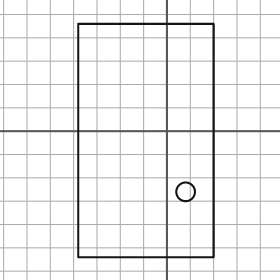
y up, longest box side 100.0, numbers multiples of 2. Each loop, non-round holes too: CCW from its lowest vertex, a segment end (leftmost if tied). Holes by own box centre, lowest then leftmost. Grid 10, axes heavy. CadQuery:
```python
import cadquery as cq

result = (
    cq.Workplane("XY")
    .moveTo(-38.0, -54.0)
    .lineTo(20.0, -54.0)
    .lineTo(20.0, 46.0)
    .lineTo(-38.0, 46.0)
    .close()
    .moveTo(8.0, -26.0)
    .circle(4.0)
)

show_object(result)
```